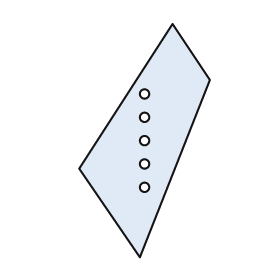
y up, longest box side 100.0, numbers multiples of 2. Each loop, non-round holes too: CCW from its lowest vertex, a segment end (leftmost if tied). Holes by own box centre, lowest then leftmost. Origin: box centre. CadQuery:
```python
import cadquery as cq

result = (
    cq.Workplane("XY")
    .moveTo(-2.0, -50.0)
    .lineTo(28.0, 26.0)
    .lineTo(12.0, 50.0)
    .lineTo(-28.0, -12.0)
    .close()
    .moveTo(0.0, -20.0)
    .circle(2.0)
    .moveTo(0.0, -10.0)
    .circle(2.0)
    .moveTo(0.0, 0.0)
    .circle(2.0)
    .moveTo(0.0, 10.0)
    .circle(2.0)
    .moveTo(0.0, 20.0)
    .circle(2.0)
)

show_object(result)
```